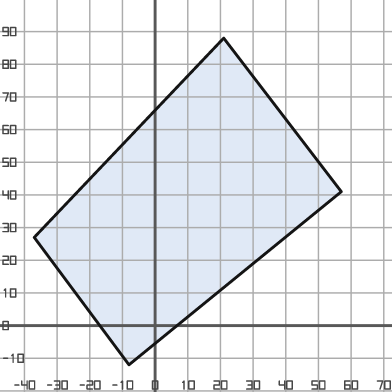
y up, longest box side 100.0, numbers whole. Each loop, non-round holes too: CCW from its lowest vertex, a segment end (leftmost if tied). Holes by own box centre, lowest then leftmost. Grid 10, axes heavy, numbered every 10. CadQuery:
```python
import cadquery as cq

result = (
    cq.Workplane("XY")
    .moveTo(-8.0, -12.0)
    .lineTo(57.0, 41.0)
    .lineTo(21.0, 88.0)
    .lineTo(-37.0, 27.0)
    .close()
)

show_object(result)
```